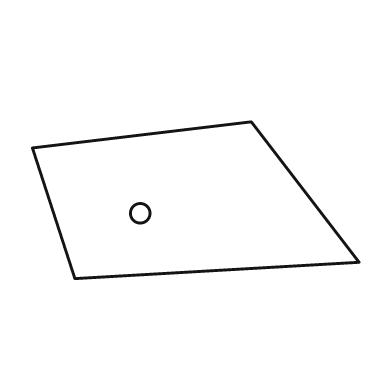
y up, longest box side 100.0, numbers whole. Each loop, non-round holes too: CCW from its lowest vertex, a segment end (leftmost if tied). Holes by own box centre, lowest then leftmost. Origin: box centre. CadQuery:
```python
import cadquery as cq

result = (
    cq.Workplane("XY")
    .moveTo(-37.0, -24.0)
    .lineTo(50.0, -19.0)
    .lineTo(17.0, 24.0)
    .lineTo(-50.0, 16.0)
    .close()
    .moveTo(-17.0, -4.0)
    .circle(3.0)
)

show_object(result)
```